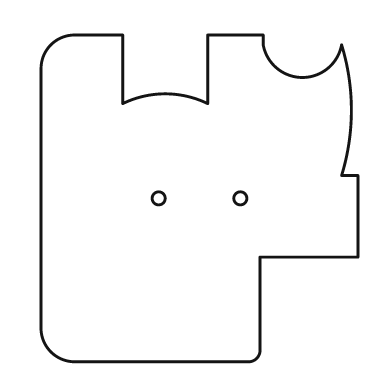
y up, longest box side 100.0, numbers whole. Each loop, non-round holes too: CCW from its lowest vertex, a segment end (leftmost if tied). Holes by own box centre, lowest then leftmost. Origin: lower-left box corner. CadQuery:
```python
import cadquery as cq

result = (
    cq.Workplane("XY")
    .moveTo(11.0, 0.0)
    .lineTo(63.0, 0.0)
    .threePointArc((66.0, 1.0), (67.0, 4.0))
    .lineTo(67.0, 32.0)
    .lineTo(97.0, 32.0)
    .lineTo(97.0, 57.0)
    .lineTo(92.0, 57.0)
    .threePointArc((95.0, 77.0), (92.0, 97.0))
    .threePointArc((80.0, 87.0), (68.0, 97.0))
    .lineTo(68.0, 100.0)
    .lineTo(51.0, 100.0)
    .lineTo(51.0, 79.0)
    .threePointArc((38.0, 82.0), (25.0, 79.0))
    .lineTo(25.0, 100.0)
    .lineTo(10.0, 100.0)
    .threePointArc((3.0, 97.0), (0.0, 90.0))
    .lineTo(0.0, 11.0)
    .threePointArc((3.0, 3.0), (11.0, 0.0))
    .close()
    .moveTo(36.0, 50.0)
    .circle(2.0)
    .moveTo(61.0, 50.0)
    .circle(2.0)
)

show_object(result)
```